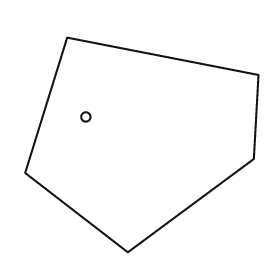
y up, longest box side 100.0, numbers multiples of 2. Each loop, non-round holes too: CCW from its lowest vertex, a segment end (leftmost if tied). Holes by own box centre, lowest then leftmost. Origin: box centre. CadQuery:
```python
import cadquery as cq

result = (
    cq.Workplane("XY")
    .moveTo(-6.0, -46.0)
    .lineTo(48.0, -6.0)
    .lineTo(50.0, 30.0)
    .lineTo(-32.0, 46.0)
    .lineTo(-50.0, -12.0)
    .close()
    .moveTo(-24.0, 12.0)
    .circle(2.0)
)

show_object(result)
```